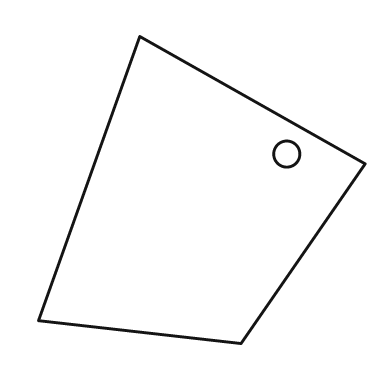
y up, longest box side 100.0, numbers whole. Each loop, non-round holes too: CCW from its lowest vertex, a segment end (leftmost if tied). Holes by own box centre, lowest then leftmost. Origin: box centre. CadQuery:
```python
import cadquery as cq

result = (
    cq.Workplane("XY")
    .moveTo(12.0, -47.0)
    .lineTo(50.0, 8.0)
    .lineTo(-19.0, 47.0)
    .lineTo(-50.0, -40.0)
    .close()
    .moveTo(26.0, 11.0)
    .circle(4.0)
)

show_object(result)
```